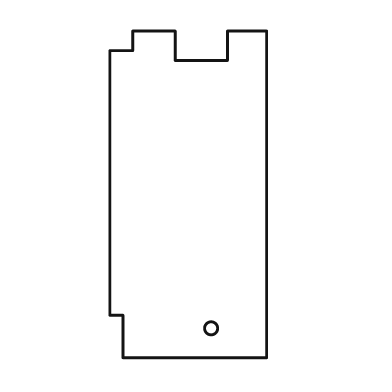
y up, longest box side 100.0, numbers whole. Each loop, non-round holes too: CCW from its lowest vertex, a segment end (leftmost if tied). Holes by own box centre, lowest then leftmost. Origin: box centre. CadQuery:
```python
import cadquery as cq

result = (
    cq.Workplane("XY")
    .moveTo(-20.0, -50.0)
    .lineTo(24.0, -50.0)
    .lineTo(24.0, 50.0)
    .lineTo(12.0, 50.0)
    .lineTo(12.0, 41.0)
    .lineTo(-4.0, 41.0)
    .lineTo(-4.0, 50.0)
    .lineTo(-17.0, 50.0)
    .lineTo(-17.0, 44.0)
    .lineTo(-24.0, 44.0)
    .lineTo(-24.0, -37.0)
    .lineTo(-20.0, -37.0)
    .close()
    .moveTo(7.0, -41.0)
    .circle(2.0)
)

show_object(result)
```